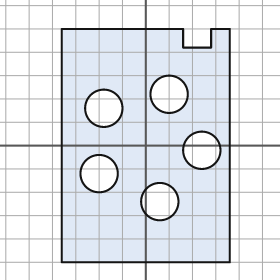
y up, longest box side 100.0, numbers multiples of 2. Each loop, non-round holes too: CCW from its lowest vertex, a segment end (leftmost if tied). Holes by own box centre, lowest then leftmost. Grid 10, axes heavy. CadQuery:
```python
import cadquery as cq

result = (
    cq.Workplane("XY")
    .moveTo(-36.0, -50.0)
    .lineTo(36.0, -50.0)
    .lineTo(36.0, 50.0)
    .lineTo(28.0, 50.0)
    .lineTo(28.0, 42.0)
    .lineTo(16.0, 42.0)
    .lineTo(16.0, 50.0)
    .lineTo(-36.0, 50.0)
    .close()
    .moveTo(6.0, -24.0)
    .circle(8.0)
    .moveTo(-20.0, -12.0)
    .circle(8.0)
    .moveTo(24.0, -2.0)
    .circle(8.0)
    .moveTo(-18.0, 16.0)
    .circle(8.0)
    .moveTo(10.0, 22.0)
    .circle(8.0)
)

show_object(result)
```